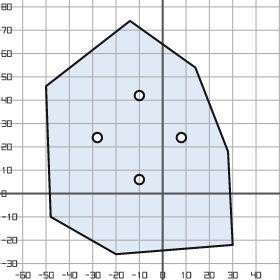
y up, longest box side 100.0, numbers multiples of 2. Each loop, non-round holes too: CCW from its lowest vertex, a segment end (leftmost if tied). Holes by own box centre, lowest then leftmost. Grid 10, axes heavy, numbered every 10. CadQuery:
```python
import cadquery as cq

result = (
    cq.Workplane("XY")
    .moveTo(-20.0, -26.0)
    .lineTo(30.0, -22.0)
    .lineTo(28.0, 18.0)
    .lineTo(14.0, 54.0)
    .lineTo(-14.0, 74.0)
    .lineTo(-50.0, 46.0)
    .lineTo(-48.0, -10.0)
    .close()
    .moveTo(-10.0, 6.0)
    .circle(2.0)
    .moveTo(-28.0, 24.0)
    .circle(2.0)
    .moveTo(8.0, 24.0)
    .circle(2.0)
    .moveTo(-10.0, 42.0)
    .circle(2.0)
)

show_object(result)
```